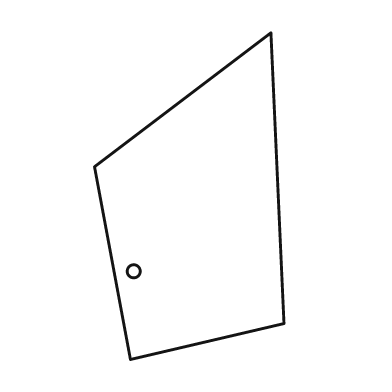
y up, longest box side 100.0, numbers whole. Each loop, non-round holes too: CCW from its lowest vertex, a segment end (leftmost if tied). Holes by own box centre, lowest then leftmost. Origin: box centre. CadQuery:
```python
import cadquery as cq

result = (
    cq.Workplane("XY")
    .moveTo(-18.0, -50.0)
    .lineTo(29.0, -39.0)
    .lineTo(25.0, 50.0)
    .lineTo(-29.0, 9.0)
    .close()
    .moveTo(-17.0, -23.0)
    .circle(2.0)
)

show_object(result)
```